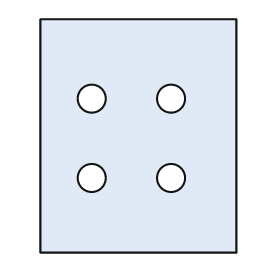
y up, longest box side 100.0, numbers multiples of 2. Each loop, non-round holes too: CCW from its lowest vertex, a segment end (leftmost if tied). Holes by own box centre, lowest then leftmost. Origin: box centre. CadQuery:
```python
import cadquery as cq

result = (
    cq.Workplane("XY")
    .moveTo(-42.0, -50.0)
    .lineTo(42.0, -50.0)
    .lineTo(42.0, 50.0)
    .lineTo(-42.0, 50.0)
    .close()
    .moveTo(-20.0, -18.0)
    .circle(6.0)
    .moveTo(14.0, -18.0)
    .circle(6.0)
    .moveTo(-20.0, 16.0)
    .circle(6.0)
    .moveTo(14.0, 16.0)
    .circle(6.0)
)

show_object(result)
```